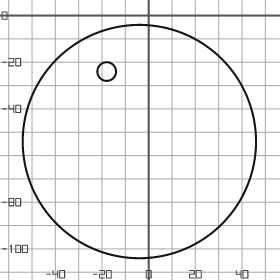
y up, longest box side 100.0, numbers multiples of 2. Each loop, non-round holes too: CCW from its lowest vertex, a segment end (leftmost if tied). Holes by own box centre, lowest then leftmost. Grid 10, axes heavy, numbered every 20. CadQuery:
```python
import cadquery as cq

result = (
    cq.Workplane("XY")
    .moveTo(-4.0, -54.0)
    .circle(50.0)
    .moveTo(-18.0, -24.0)
    .circle(4.0)
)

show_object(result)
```